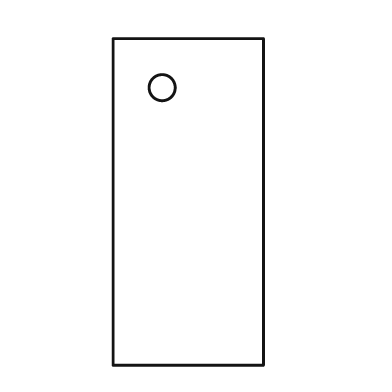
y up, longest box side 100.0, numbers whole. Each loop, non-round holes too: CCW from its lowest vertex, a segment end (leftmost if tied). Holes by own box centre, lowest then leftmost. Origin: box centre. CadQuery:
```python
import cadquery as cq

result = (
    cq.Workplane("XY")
    .moveTo(-23.0, -50.0)
    .lineTo(23.0, -50.0)
    .lineTo(23.0, 50.0)
    .lineTo(-23.0, 50.0)
    .close()
    .moveTo(-8.0, 35.0)
    .circle(4.0)
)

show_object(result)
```